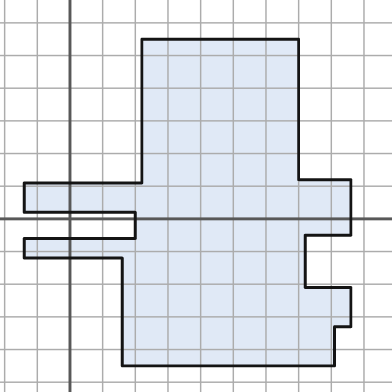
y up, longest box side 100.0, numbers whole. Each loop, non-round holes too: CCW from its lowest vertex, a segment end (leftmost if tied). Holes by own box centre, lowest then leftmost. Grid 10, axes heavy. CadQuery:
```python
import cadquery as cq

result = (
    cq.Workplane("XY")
    .moveTo(16.0, -45.0)
    .lineTo(81.0, -45.0)
    .lineTo(81.0, -33.0)
    .lineTo(86.0, -33.0)
    .lineTo(86.0, -21.0)
    .lineTo(72.0, -21.0)
    .lineTo(72.0, -5.0)
    .lineTo(86.0, -5.0)
    .lineTo(86.0, 12.0)
    .lineTo(70.0, 12.0)
    .lineTo(70.0, 55.0)
    .lineTo(22.0, 55.0)
    .lineTo(22.0, 11.0)
    .lineTo(-14.0, 11.0)
    .lineTo(-14.0, 2.0)
    .lineTo(20.0, 2.0)
    .lineTo(20.0, -6.0)
    .lineTo(-14.0, -6.0)
    .lineTo(-14.0, -12.0)
    .lineTo(16.0, -12.0)
    .close()
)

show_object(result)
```